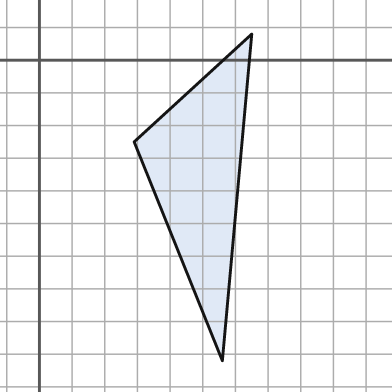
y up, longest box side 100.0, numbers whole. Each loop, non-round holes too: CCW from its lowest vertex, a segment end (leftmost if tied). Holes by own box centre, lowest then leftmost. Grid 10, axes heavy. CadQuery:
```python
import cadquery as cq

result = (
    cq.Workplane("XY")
    .moveTo(56.0, -92.0)
    .lineTo(65.0, 8.0)
    .lineTo(29.0, -25.0)
    .close()
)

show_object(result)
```